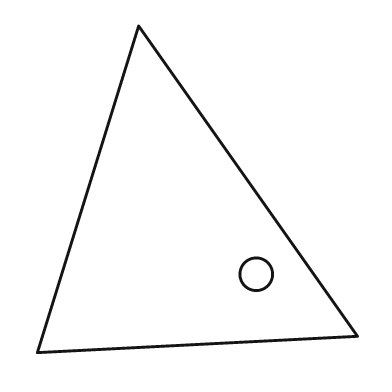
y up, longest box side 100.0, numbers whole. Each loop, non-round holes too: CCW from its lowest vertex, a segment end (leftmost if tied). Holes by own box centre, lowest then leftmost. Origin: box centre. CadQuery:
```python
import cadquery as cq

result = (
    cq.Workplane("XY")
    .moveTo(-49.0, -50.0)
    .lineTo(49.0, -45.0)
    .lineTo(-18.0, 50.0)
    .close()
    .moveTo(18.0, -26.0)
    .circle(5.0)
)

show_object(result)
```